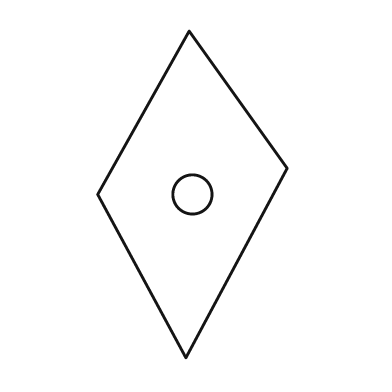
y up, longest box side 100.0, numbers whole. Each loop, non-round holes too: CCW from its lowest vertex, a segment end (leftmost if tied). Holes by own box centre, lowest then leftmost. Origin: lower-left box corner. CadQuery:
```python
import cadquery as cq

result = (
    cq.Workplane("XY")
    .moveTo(27.0, 0.0)
    .lineTo(58.0, 58.0)
    .lineTo(28.0, 100.0)
    .lineTo(0.0, 50.0)
    .close()
    .moveTo(29.0, 50.0)
    .circle(6.0)
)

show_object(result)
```